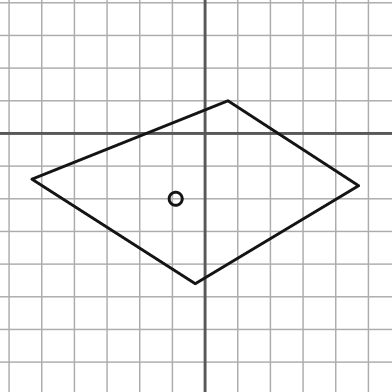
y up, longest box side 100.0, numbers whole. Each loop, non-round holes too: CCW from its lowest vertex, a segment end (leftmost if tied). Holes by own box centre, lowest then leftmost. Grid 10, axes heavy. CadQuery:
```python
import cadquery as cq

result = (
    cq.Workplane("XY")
    .moveTo(-3.0, -46.0)
    .lineTo(47.0, -16.0)
    .lineTo(7.0, 10.0)
    .lineTo(-53.0, -14.0)
    .close()
    .moveTo(-9.0, -20.0)
    .circle(2.0)
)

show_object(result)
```